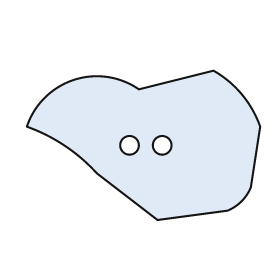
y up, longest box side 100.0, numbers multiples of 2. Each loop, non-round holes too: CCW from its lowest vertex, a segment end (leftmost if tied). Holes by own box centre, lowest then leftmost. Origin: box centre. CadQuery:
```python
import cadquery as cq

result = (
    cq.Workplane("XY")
    .moveTo(6.0, -32.0)
    .lineTo(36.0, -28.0)
    .threePointArc((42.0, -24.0), (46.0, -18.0))
    .lineTo(50.0, 8.0)
    .threePointArc((42.0, 22.0), (30.0, 32.0))
    .lineTo(-2.0, 24.0)
    .threePointArc((-30.0, 28.0), (-50.0, 8.0))
    .threePointArc((-34.0, 0.0), (-20.0, -12.0))
    .close()
    .moveTo(-6.0, 0.0)
    .circle(4.0)
    .moveTo(8.0, 0.0)
    .circle(4.0)
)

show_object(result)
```